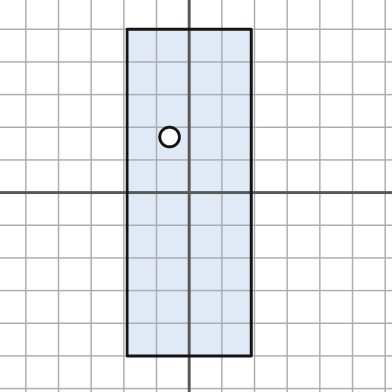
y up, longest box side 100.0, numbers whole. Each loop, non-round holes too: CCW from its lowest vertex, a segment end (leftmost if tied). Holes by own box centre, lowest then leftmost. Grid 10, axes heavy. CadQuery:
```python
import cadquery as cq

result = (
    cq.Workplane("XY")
    .moveTo(-19.0, -50.0)
    .lineTo(19.0, -50.0)
    .lineTo(19.0, 50.0)
    .lineTo(-19.0, 50.0)
    .close()
    .moveTo(-6.0, 17.0)
    .circle(3.0)
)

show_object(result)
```